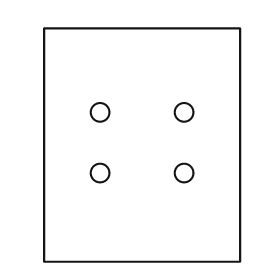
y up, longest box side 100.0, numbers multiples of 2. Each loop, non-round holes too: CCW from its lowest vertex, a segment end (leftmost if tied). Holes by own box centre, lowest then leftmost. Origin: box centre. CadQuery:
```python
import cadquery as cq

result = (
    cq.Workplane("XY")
    .moveTo(-42.0, -50.0)
    .lineTo(42.0, -50.0)
    .lineTo(42.0, 50.0)
    .lineTo(-42.0, 50.0)
    .close()
    .moveTo(-18.0, -12.0)
    .circle(4.0)
    .moveTo(18.0, -12.0)
    .circle(4.0)
    .moveTo(-18.0, 14.0)
    .circle(4.0)
    .moveTo(18.0, 14.0)
    .circle(4.0)
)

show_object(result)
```